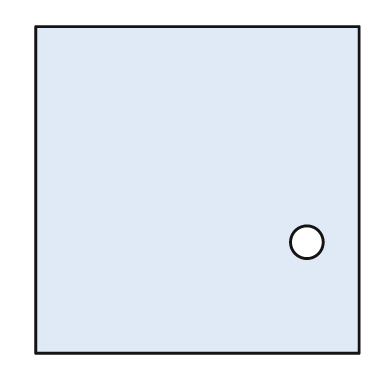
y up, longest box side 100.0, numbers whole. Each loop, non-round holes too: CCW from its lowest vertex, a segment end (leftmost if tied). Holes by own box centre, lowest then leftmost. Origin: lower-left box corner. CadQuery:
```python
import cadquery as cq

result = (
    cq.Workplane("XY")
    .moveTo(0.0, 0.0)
    .lineTo(99.0, 0.0)
    .lineTo(99.0, 100.0)
    .lineTo(0.0, 100.0)
    .close()
    .moveTo(83.0, 34.0)
    .circle(5.0)
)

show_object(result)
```